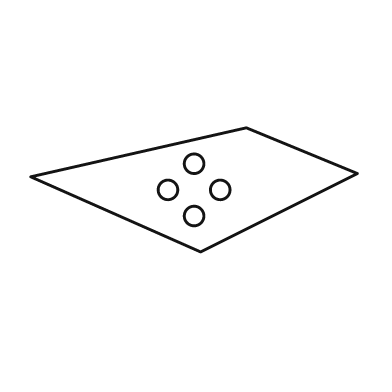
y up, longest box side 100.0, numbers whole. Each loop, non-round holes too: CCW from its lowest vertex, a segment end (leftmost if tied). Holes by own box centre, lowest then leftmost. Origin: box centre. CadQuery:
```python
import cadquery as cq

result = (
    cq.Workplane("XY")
    .moveTo(2.0, -19.0)
    .lineTo(50.0, 5.0)
    .lineTo(16.0, 19.0)
    .lineTo(-50.0, 4.0)
    .close()
    .moveTo(0.0, -8.0)
    .circle(3.0)
    .moveTo(-8.0, 0.0)
    .circle(3.0)
    .moveTo(8.0, 0.0)
    .circle(3.0)
    .moveTo(0.0, 8.0)
    .circle(3.0)
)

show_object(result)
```